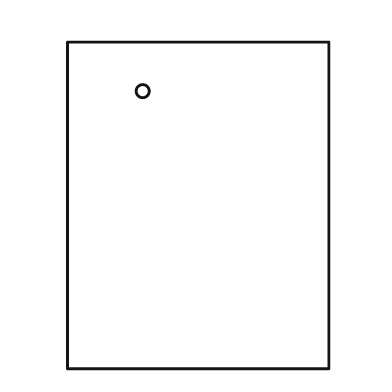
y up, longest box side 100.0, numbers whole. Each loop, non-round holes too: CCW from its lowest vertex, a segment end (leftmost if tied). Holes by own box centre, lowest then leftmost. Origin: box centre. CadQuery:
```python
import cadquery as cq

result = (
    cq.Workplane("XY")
    .moveTo(-40.0, -50.0)
    .lineTo(40.0, -50.0)
    .lineTo(40.0, 50.0)
    .lineTo(-40.0, 50.0)
    .close()
    .moveTo(-17.0, 35.0)
    .circle(2.0)
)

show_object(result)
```